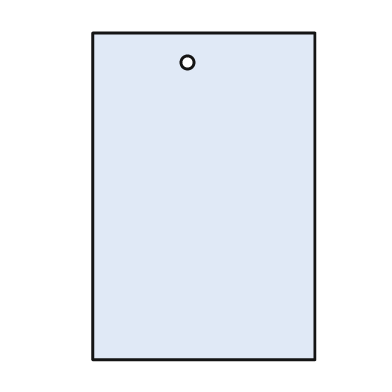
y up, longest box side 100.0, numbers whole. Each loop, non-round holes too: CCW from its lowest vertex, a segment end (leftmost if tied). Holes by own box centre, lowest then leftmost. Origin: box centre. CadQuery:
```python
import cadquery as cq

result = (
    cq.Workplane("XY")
    .moveTo(-34.0, -50.0)
    .lineTo(34.0, -50.0)
    .lineTo(34.0, 50.0)
    .lineTo(-34.0, 50.0)
    .close()
    .moveTo(-5.0, 41.0)
    .circle(2.0)
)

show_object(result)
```